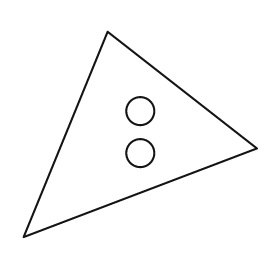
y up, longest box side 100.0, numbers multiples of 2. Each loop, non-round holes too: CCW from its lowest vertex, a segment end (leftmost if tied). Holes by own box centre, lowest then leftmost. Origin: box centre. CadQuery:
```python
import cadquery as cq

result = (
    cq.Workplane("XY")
    .moveTo(-50.0, -44.0)
    .lineTo(50.0, -6.0)
    .lineTo(-14.0, 44.0)
    .close()
    .moveTo(0.0, -8.0)
    .circle(6.0)
    .moveTo(0.0, 10.0)
    .circle(6.0)
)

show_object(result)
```